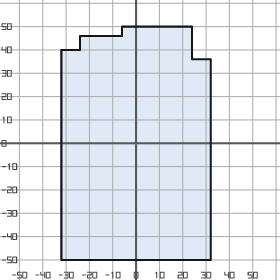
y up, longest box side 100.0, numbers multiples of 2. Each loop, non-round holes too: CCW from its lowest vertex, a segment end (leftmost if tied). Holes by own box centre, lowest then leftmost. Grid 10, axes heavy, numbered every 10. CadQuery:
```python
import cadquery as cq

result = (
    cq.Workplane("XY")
    .moveTo(-32.0, -50.0)
    .lineTo(32.0, -50.0)
    .lineTo(32.0, 36.0)
    .lineTo(24.0, 36.0)
    .lineTo(24.0, 50.0)
    .lineTo(-6.0, 50.0)
    .lineTo(-6.0, 46.0)
    .lineTo(-24.0, 46.0)
    .lineTo(-24.0, 40.0)
    .lineTo(-32.0, 40.0)
    .close()
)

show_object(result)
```